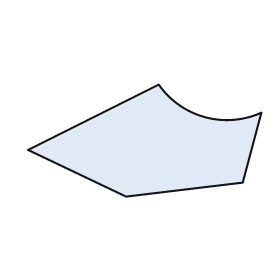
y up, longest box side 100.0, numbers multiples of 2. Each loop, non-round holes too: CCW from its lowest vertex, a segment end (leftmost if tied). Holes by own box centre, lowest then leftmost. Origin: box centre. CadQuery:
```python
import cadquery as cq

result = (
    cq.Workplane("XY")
    .moveTo(-8.0, -24.0)
    .lineTo(42.0, -18.0)
    .lineTo(50.0, 12.0)
    .threePointArc((26.0, 10.0), (6.0, 24.0))
    .lineTo(-50.0, -4.0)
    .close()
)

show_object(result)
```